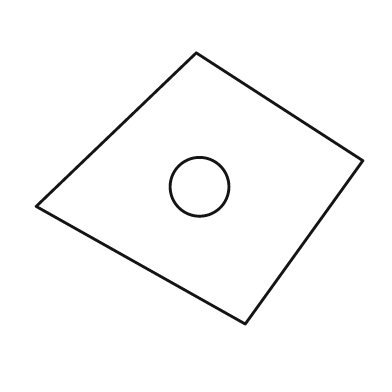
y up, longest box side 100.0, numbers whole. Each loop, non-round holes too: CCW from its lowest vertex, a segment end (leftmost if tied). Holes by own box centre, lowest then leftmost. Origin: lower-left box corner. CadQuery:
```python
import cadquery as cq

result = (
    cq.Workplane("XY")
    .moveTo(64.0, 0.0)
    .lineTo(100.0, 50.0)
    .lineTo(49.0, 83.0)
    .lineTo(0.0, 36.0)
    .close()
    .moveTo(50.0, 42.0)
    .circle(9.0)
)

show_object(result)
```